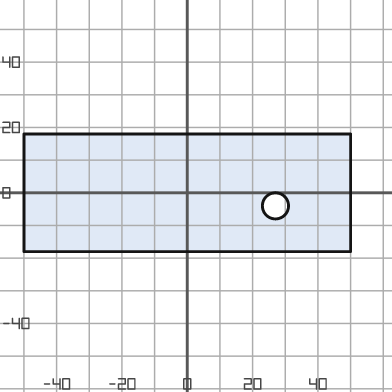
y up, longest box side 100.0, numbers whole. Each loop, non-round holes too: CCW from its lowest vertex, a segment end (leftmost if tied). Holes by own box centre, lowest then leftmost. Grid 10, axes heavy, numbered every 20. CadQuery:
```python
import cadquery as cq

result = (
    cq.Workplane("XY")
    .moveTo(-50.0, -18.0)
    .lineTo(50.0, -18.0)
    .lineTo(50.0, 18.0)
    .lineTo(-50.0, 18.0)
    .close()
    .moveTo(27.0, -4.0)
    .circle(4.0)
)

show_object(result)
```